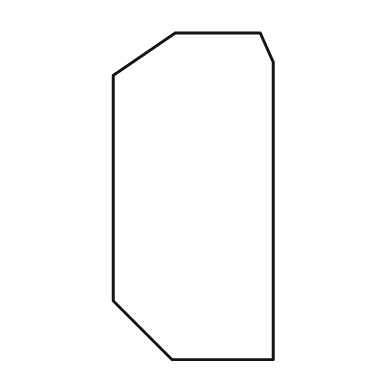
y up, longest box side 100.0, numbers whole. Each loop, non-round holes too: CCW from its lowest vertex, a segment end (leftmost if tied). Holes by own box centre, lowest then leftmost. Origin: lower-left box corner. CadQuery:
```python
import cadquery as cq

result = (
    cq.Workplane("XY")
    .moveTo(18.0, 0.0)
    .lineTo(49.0, 0.0)
    .lineTo(49.0, 91.0)
    .lineTo(45.0, 100.0)
    .lineTo(19.0, 100.0)
    .lineTo(0.0, 87.0)
    .lineTo(0.0, 18.0)
    .close()
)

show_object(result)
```